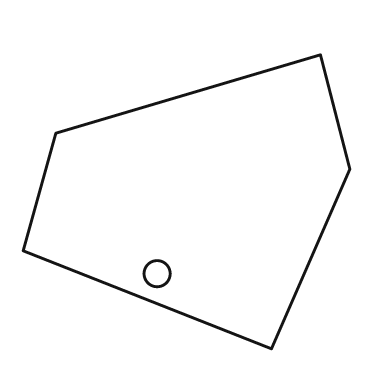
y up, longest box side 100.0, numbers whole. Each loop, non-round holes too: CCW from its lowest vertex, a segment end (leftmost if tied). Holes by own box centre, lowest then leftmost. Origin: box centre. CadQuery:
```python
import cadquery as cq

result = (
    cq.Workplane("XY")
    .moveTo(26.0, -45.0)
    .lineTo(50.0, 10.0)
    .lineTo(41.0, 45.0)
    .lineTo(-40.0, 21.0)
    .lineTo(-50.0, -15.0)
    .close()
    .moveTo(-9.0, -22.0)
    .circle(4.0)
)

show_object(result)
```